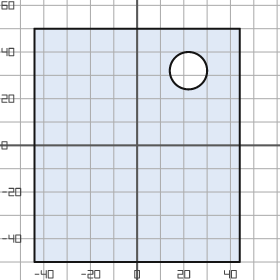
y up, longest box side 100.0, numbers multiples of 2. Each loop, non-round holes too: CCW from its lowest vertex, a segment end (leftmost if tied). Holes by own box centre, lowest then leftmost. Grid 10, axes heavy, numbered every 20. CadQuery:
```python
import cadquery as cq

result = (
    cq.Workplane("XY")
    .moveTo(-44.0, -50.0)
    .lineTo(44.0, -50.0)
    .lineTo(44.0, 50.0)
    .lineTo(-44.0, 50.0)
    .close()
    .moveTo(22.0, 32.0)
    .circle(8.0)
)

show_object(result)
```